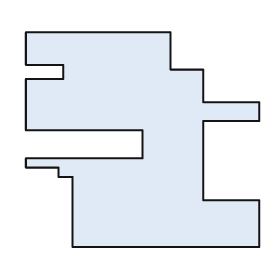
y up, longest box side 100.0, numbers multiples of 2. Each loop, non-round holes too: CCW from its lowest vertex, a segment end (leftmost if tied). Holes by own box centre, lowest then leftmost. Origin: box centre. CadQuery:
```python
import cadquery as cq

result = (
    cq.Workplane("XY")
    .moveTo(-30.0, -46.0)
    .lineTo(50.0, -46.0)
    .lineTo(50.0, -26.0)
    .lineTo(26.0, -26.0)
    .lineTo(26.0, 8.0)
    .lineTo(50.0, 8.0)
    .lineTo(50.0, 16.0)
    .lineTo(26.0, 16.0)
    .lineTo(26.0, 30.0)
    .lineTo(12.0, 30.0)
    .lineTo(12.0, 46.0)
    .lineTo(-50.0, 46.0)
    .lineTo(-50.0, 32.0)
    .lineTo(-34.0, 32.0)
    .lineTo(-34.0, 26.0)
    .lineTo(-50.0, 26.0)
    .lineTo(-50.0, 4.0)
    .lineTo(0.0, 4.0)
    .lineTo(0.0, -8.0)
    .lineTo(-50.0, -8.0)
    .lineTo(-50.0, -12.0)
    .lineTo(-36.0, -12.0)
    .lineTo(-36.0, -16.0)
    .lineTo(-30.0, -16.0)
    .close()
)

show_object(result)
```